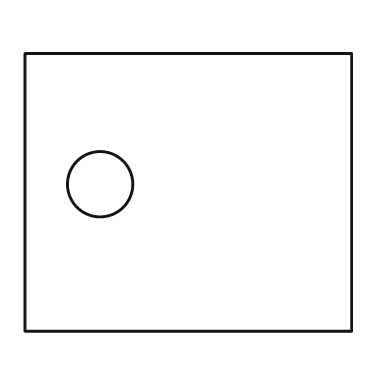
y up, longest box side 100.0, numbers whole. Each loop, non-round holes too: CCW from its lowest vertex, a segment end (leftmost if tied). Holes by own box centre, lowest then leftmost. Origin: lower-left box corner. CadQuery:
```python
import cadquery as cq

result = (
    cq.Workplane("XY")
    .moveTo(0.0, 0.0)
    .lineTo(100.0, 0.0)
    .lineTo(100.0, 85.0)
    .lineTo(0.0, 85.0)
    .close()
    .moveTo(23.0, 45.0)
    .circle(10.0)
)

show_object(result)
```